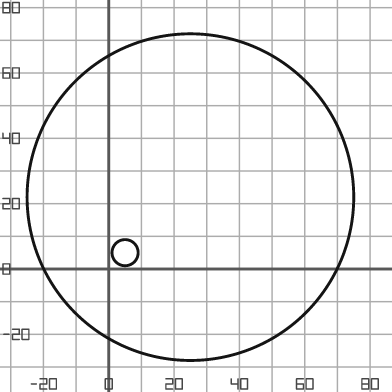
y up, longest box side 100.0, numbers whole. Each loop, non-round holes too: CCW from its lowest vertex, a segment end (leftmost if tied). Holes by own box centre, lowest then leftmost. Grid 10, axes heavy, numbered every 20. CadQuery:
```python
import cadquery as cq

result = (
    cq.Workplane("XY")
    .moveTo(25.0, 22.0)
    .circle(50.0)
    .moveTo(5.0, 5.0)
    .circle(4.0)
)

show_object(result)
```